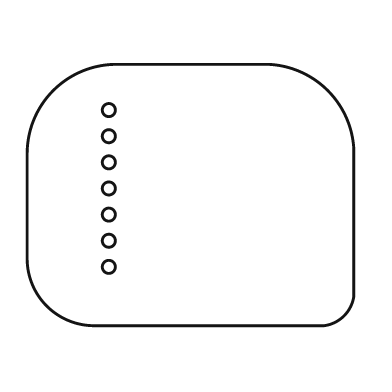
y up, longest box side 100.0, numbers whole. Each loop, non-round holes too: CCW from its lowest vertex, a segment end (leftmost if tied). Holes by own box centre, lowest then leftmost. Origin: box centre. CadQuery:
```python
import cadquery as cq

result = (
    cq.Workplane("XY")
    .moveTo(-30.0, -40.0)
    .lineTo(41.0, -40.0)
    .threePointArc((47.0, -37.0), (50.0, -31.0))
    .lineTo(50.0, 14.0)
    .threePointArc((42.0, 32.0), (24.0, 40.0))
    .lineTo(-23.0, 40.0)
    .threePointArc((-42.0, 32.0), (-50.0, 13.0))
    .lineTo(-50.0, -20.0)
    .threePointArc((-44.0, -34.0), (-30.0, -40.0))
    .close()
    .moveTo(-25.0, -22.0)
    .circle(2.0)
    .moveTo(-25.0, -14.0)
    .circle(2.0)
    .moveTo(-25.0, -6.0)
    .circle(2.0)
    .moveTo(-25.0, 2.0)
    .circle(2.0)
    .moveTo(-25.0, 10.0)
    .circle(2.0)
    .moveTo(-25.0, 18.0)
    .circle(2.0)
    .moveTo(-25.0, 26.0)
    .circle(2.0)
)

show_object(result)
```